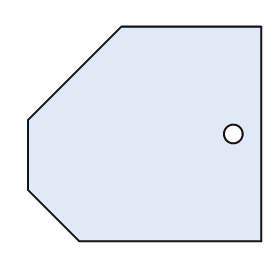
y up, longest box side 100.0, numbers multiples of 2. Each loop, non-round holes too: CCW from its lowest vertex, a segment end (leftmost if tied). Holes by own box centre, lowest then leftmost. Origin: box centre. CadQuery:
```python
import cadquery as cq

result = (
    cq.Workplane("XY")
    .moveTo(-28.0, -46.0)
    .lineTo(50.0, -46.0)
    .lineTo(50.0, 46.0)
    .lineTo(-10.0, 46.0)
    .lineTo(-50.0, 6.0)
    .lineTo(-50.0, -24.0)
    .close()
    .moveTo(38.0, 0.0)
    .circle(4.0)
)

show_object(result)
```